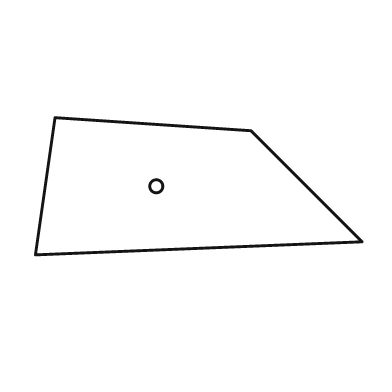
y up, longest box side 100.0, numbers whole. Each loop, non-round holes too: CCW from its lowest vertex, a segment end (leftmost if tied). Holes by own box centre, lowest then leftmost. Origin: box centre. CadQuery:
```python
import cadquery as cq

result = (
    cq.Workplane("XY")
    .moveTo(-50.0, -21.0)
    .lineTo(50.0, -17.0)
    .lineTo(16.0, 17.0)
    .lineTo(-44.0, 21.0)
    .close()
    .moveTo(-13.0, 0.0)
    .circle(2.0)
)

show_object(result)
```